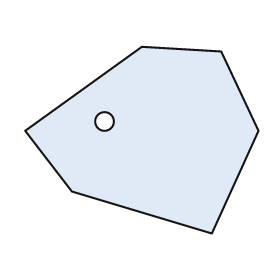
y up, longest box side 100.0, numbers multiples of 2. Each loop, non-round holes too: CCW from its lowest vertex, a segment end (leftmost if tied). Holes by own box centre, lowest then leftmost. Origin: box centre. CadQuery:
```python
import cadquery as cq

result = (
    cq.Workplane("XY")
    .moveTo(30.0, -40.0)
    .lineTo(50.0, 4.0)
    .lineTo(34.0, 38.0)
    .lineTo(0.0, 40.0)
    .lineTo(-50.0, 4.0)
    .lineTo(-30.0, -22.0)
    .close()
    .moveTo(-16.0, 8.0)
    .circle(4.0)
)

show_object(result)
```